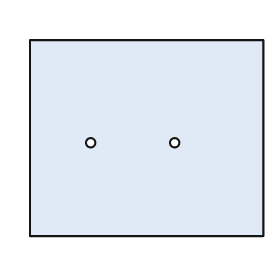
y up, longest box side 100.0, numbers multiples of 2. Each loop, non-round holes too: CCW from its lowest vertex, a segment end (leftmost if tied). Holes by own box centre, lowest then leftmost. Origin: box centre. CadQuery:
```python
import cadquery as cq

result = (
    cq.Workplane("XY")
    .moveTo(-50.0, -42.0)
    .lineTo(50.0, -42.0)
    .lineTo(50.0, 42.0)
    .lineTo(-50.0, 42.0)
    .close()
    .moveTo(-24.0, -2.0)
    .circle(2.0)
    .moveTo(12.0, -2.0)
    .circle(2.0)
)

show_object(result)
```